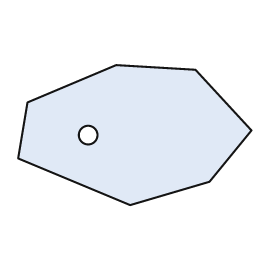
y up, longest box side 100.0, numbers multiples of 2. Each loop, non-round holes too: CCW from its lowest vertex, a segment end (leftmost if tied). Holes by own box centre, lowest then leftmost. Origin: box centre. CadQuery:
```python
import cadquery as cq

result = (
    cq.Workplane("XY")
    .moveTo(-2.0, -30.0)
    .lineTo(32.0, -20.0)
    .lineTo(50.0, 2.0)
    .lineTo(26.0, 28.0)
    .lineTo(-8.0, 30.0)
    .lineTo(-46.0, 14.0)
    .lineTo(-50.0, -10.0)
    .close()
    .moveTo(-20.0, 0.0)
    .circle(4.0)
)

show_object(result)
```